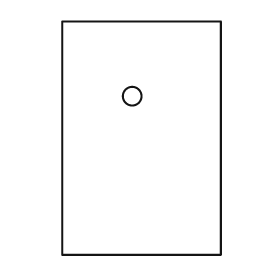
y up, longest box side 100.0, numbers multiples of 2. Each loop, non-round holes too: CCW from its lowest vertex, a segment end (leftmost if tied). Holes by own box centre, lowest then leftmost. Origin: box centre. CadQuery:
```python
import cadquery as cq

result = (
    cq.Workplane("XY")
    .moveTo(-34.0, -50.0)
    .lineTo(34.0, -50.0)
    .lineTo(34.0, 50.0)
    .lineTo(-34.0, 50.0)
    .close()
    .moveTo(-4.0, 18.0)
    .circle(4.0)
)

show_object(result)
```